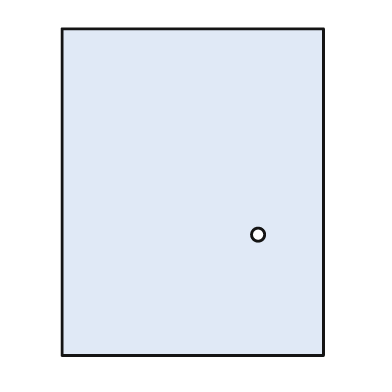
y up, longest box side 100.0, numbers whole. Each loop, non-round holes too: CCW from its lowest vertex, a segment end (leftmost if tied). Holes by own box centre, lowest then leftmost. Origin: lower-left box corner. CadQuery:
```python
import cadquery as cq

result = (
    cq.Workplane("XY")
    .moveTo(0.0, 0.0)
    .lineTo(80.0, 0.0)
    .lineTo(80.0, 100.0)
    .lineTo(0.0, 100.0)
    .close()
    .moveTo(60.0, 37.0)
    .circle(2.0)
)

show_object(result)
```